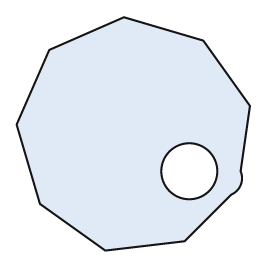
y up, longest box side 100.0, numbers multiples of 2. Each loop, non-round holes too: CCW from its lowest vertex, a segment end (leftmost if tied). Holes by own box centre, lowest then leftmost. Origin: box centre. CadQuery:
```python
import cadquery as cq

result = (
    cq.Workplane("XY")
    .moveTo(-12.0, -50.0)
    .lineTo(22.0, -46.0)
    .lineTo(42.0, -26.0)
    .threePointArc((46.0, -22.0), (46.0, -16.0))
    .lineTo(50.0, 12.0)
    .lineTo(30.0, 40.0)
    .lineTo(-4.0, 50.0)
    .lineTo(-36.0, 36.0)
    .lineTo(-50.0, 4.0)
    .lineTo(-40.0, -30.0)
    .close()
    .moveTo(24.0, -16.0)
    .circle(12.0)
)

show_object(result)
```